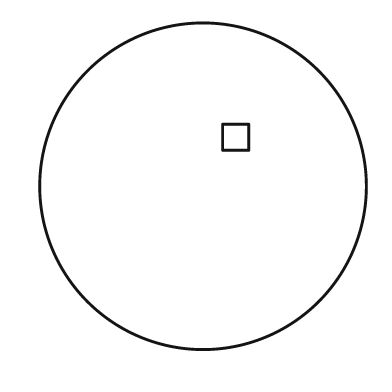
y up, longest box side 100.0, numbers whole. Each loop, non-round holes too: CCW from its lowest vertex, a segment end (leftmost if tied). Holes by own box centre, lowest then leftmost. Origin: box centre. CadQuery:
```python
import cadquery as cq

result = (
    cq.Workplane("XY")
    .moveTo(0.0, 0.0)
    .circle(50.0)
    .moveTo(6.0, 11.0)
    .lineTo(14.0, 11.0)
    .lineTo(14.0, 19.0)
    .lineTo(6.0, 19.0)
    .close()
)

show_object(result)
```